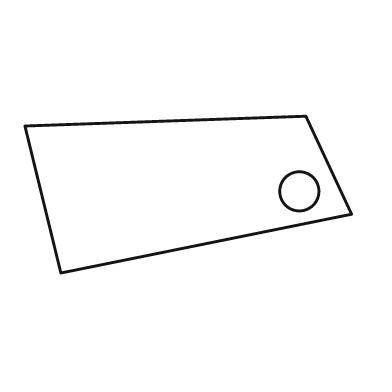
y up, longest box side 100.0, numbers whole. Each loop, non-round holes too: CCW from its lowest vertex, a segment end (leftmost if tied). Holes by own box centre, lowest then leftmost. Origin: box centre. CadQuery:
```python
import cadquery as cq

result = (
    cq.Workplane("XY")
    .moveTo(-39.0, -24.0)
    .lineTo(50.0, -6.0)
    .lineTo(36.0, 24.0)
    .lineTo(-50.0, 21.0)
    .close()
    .moveTo(34.0, 1.0)
    .circle(6.0)
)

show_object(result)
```